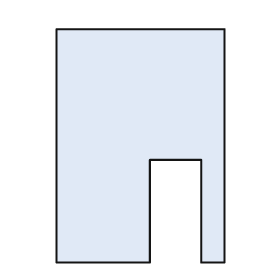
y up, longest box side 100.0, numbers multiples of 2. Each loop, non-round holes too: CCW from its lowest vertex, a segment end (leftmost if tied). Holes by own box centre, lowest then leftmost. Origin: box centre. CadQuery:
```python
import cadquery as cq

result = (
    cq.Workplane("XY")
    .moveTo(-36.0, -50.0)
    .lineTo(4.0, -50.0)
    .lineTo(4.0, -6.0)
    .lineTo(26.0, -6.0)
    .lineTo(26.0, -50.0)
    .lineTo(36.0, -50.0)
    .lineTo(36.0, 50.0)
    .lineTo(-36.0, 50.0)
    .close()
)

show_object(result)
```